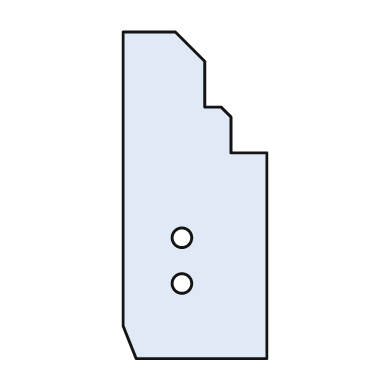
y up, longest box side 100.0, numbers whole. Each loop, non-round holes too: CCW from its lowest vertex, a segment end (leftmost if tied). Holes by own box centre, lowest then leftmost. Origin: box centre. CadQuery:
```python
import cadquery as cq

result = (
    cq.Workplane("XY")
    .moveTo(-18.0, -50.0)
    .lineTo(22.0, -50.0)
    .lineTo(22.0, 13.0)
    .lineTo(11.0, 13.0)
    .lineTo(11.0, 24.0)
    .lineTo(8.0, 27.0)
    .lineTo(3.0, 27.0)
    .lineTo(3.0, 41.0)
    .lineTo(-6.0, 50.0)
    .lineTo(-22.0, 50.0)
    .lineTo(-22.0, -40.0)
    .close()
    .moveTo(-4.0, -27.0)
    .circle(3.0)
    .moveTo(-4.0, -13.0)
    .circle(3.0)
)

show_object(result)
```